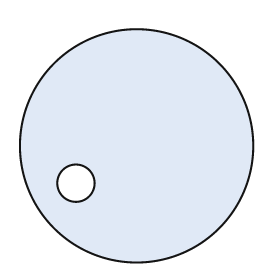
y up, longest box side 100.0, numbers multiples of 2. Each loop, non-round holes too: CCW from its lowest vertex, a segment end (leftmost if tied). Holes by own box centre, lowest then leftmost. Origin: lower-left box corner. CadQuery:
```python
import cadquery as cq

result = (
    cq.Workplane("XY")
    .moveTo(50.0, 50.0)
    .circle(50.0)
    .moveTo(24.0, 34.0)
    .circle(8.0)
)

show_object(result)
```